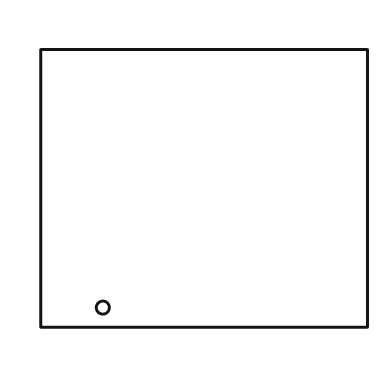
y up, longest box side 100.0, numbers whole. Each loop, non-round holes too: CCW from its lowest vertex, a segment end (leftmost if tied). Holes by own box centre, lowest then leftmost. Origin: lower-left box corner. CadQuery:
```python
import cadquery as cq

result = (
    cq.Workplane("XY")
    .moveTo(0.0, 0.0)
    .lineTo(100.0, 0.0)
    .lineTo(100.0, 85.0)
    .lineTo(0.0, 85.0)
    .close()
    .moveTo(19.0, 6.0)
    .circle(2.0)
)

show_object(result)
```